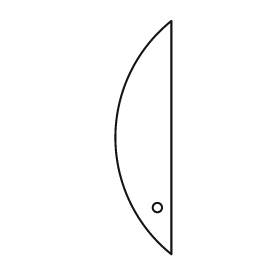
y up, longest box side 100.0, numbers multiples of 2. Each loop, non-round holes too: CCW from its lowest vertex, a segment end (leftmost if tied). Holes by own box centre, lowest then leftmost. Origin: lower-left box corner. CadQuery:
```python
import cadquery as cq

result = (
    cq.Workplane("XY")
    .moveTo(24.0, 0.0)
    .lineTo(24.0, 100.0)
    .threePointArc((0.0, 50.0), (24.0, 0.0))
    .close()
    .moveTo(18.0, 20.0)
    .circle(2.0)
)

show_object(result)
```